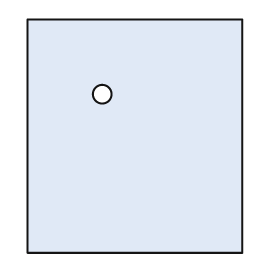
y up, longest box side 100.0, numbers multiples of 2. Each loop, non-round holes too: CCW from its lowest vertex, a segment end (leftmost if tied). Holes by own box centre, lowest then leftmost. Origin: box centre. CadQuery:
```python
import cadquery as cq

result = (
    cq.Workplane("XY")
    .moveTo(-46.0, -50.0)
    .lineTo(46.0, -50.0)
    .lineTo(46.0, 50.0)
    .lineTo(-46.0, 50.0)
    .close()
    .moveTo(-14.0, 18.0)
    .circle(4.0)
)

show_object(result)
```